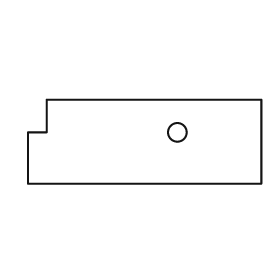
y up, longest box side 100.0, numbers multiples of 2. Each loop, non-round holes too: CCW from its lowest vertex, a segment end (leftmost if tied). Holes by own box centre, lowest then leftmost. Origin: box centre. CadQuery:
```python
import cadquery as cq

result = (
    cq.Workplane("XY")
    .moveTo(-50.0, -18.0)
    .lineTo(50.0, -18.0)
    .lineTo(50.0, 18.0)
    .lineTo(-42.0, 18.0)
    .lineTo(-42.0, 4.0)
    .lineTo(-50.0, 4.0)
    .close()
    .moveTo(14.0, 4.0)
    .circle(4.0)
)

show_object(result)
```